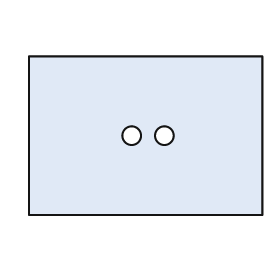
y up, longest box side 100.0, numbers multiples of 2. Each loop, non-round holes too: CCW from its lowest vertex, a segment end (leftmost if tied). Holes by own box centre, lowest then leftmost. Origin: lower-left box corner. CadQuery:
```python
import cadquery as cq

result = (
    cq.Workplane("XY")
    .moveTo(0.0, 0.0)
    .lineTo(100.0, 0.0)
    .lineTo(100.0, 68.0)
    .lineTo(0.0, 68.0)
    .close()
    .moveTo(44.0, 34.0)
    .circle(4.0)
    .moveTo(58.0, 34.0)
    .circle(4.0)
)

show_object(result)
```